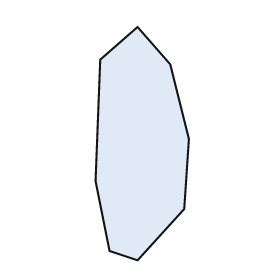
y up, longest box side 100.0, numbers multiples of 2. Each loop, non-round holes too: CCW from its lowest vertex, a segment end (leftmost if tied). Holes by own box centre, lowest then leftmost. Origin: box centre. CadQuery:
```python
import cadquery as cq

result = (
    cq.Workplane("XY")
    .moveTo(-2.0, -50.0)
    .lineTo(18.0, -28.0)
    .lineTo(20.0, 2.0)
    .lineTo(12.0, 34.0)
    .lineTo(-2.0, 50.0)
    .lineTo(-18.0, 36.0)
    .lineTo(-20.0, -16.0)
    .lineTo(-14.0, -46.0)
    .close()
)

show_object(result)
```